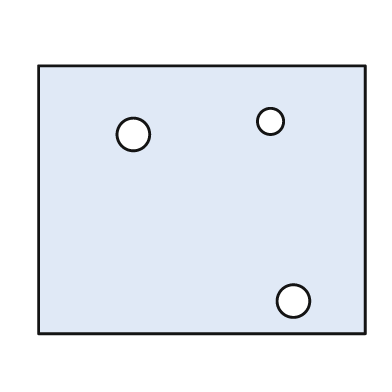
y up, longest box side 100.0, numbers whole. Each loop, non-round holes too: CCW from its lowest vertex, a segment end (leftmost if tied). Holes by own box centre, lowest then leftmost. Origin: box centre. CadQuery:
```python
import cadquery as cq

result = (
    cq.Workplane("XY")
    .moveTo(-50.0, -41.0)
    .lineTo(50.0, -41.0)
    .lineTo(50.0, 41.0)
    .lineTo(-50.0, 41.0)
    .close()
    .moveTo(28.0, -31.0)
    .circle(5.0)
    .moveTo(-21.0, 20.0)
    .circle(5.0)
    .moveTo(21.0, 24.0)
    .circle(4.0)
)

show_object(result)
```